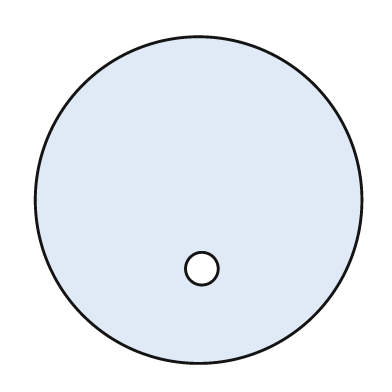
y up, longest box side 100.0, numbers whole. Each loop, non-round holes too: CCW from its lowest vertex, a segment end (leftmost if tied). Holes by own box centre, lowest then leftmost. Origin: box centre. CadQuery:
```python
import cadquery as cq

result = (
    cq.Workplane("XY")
    .moveTo(0.0, 0.0)
    .circle(50.0)
    .moveTo(1.0, -21.0)
    .circle(5.0)
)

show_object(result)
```